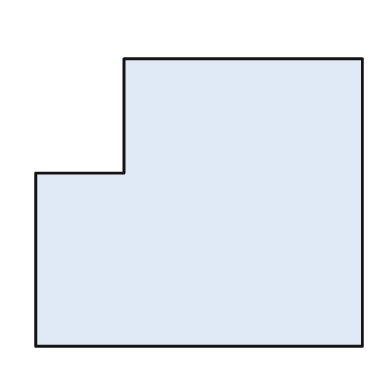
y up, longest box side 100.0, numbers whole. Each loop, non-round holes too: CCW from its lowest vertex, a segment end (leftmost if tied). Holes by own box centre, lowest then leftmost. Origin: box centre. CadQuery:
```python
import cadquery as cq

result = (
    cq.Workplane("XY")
    .moveTo(-50.0, -44.0)
    .lineTo(50.0, -44.0)
    .lineTo(50.0, 44.0)
    .lineTo(-23.0, 44.0)
    .lineTo(-23.0, 9.0)
    .lineTo(-50.0, 9.0)
    .close()
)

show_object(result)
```